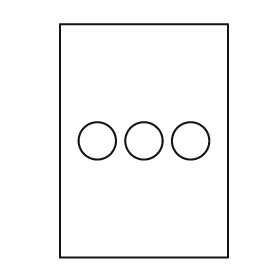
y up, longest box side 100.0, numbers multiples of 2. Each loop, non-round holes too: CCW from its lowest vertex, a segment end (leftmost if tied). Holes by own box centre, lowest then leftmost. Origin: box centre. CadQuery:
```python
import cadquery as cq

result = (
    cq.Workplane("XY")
    .moveTo(-36.0, -50.0)
    .lineTo(36.0, -50.0)
    .lineTo(36.0, 50.0)
    .lineTo(-36.0, 50.0)
    .close()
    .moveTo(-20.0, 0.0)
    .circle(8.0)
    .moveTo(0.0, 0.0)
    .circle(8.0)
    .moveTo(20.0, 0.0)
    .circle(8.0)
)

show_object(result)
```